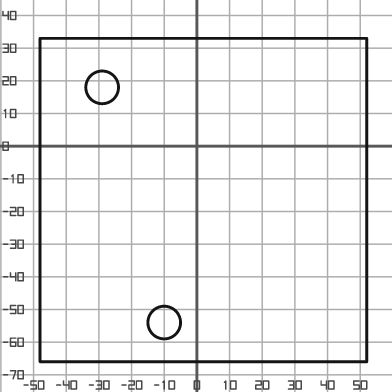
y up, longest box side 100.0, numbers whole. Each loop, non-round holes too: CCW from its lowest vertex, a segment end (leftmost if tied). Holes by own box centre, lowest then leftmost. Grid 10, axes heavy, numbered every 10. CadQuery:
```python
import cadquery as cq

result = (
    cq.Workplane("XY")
    .moveTo(-48.0, -66.0)
    .lineTo(52.0, -66.0)
    .lineTo(52.0, 33.0)
    .lineTo(-48.0, 33.0)
    .close()
    .moveTo(-10.0, -54.0)
    .circle(5.0)
    .moveTo(-29.0, 18.0)
    .circle(5.0)
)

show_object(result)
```